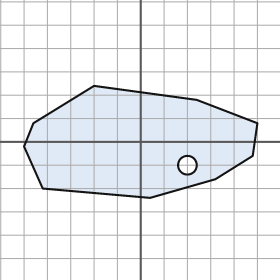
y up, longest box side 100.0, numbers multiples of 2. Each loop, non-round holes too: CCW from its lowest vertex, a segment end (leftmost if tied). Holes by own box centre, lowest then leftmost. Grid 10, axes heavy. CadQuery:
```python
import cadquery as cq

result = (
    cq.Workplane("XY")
    .moveTo(4.0, -24.0)
    .lineTo(32.0, -16.0)
    .lineTo(48.0, -6.0)
    .lineTo(50.0, 8.0)
    .lineTo(24.0, 18.0)
    .lineTo(-20.0, 24.0)
    .lineTo(-46.0, 8.0)
    .lineTo(-50.0, -2.0)
    .lineTo(-42.0, -20.0)
    .close()
    .moveTo(20.0, -10.0)
    .circle(4.0)
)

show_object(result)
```